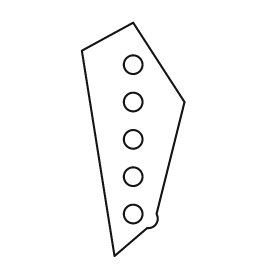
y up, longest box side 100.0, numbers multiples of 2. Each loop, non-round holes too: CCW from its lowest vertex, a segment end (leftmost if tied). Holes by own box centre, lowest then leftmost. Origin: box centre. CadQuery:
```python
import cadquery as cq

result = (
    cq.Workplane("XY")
    .moveTo(-8.0, -50.0)
    .lineTo(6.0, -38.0)
    .threePointArc((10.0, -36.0), (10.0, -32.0))
    .lineTo(22.0, 16.0)
    .lineTo(0.0, 50.0)
    .lineTo(-22.0, 38.0)
    .close()
    .moveTo(0.0, -32.0)
    .circle(4.0)
    .moveTo(0.0, -16.0)
    .circle(4.0)
    .moveTo(0.0, 0.0)
    .circle(4.0)
    .moveTo(0.0, 16.0)
    .circle(4.0)
    .moveTo(0.0, 32.0)
    .circle(4.0)
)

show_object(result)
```